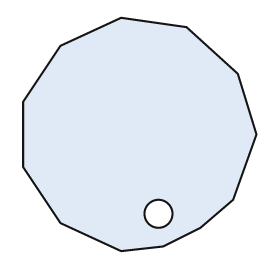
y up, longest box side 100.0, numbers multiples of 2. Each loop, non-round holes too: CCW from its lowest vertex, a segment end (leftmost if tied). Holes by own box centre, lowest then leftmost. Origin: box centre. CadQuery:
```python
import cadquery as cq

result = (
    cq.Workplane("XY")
    .moveTo(-8.0, -50.0)
    .lineTo(10.0, -48.0)
    .lineTo(26.0, -40.0)
    .lineTo(40.0, -28.0)
    .lineTo(50.0, 0.0)
    .lineTo(42.0, 26.0)
    .lineTo(20.0, 46.0)
    .lineTo(-8.0, 50.0)
    .lineTo(-34.0, 38.0)
    .lineTo(-50.0, 14.0)
    .lineTo(-50.0, -14.0)
    .lineTo(-34.0, -38.0)
    .close()
    .moveTo(8.0, -34.0)
    .circle(6.0)
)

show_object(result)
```